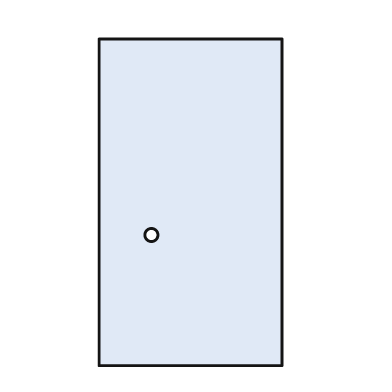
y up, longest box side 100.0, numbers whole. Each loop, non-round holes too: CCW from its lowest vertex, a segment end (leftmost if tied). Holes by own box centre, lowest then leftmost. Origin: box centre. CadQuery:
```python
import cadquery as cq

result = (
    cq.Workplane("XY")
    .moveTo(-28.0, -50.0)
    .lineTo(28.0, -50.0)
    .lineTo(28.0, 50.0)
    .lineTo(-28.0, 50.0)
    .close()
    .moveTo(-12.0, -10.0)
    .circle(2.0)
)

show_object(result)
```